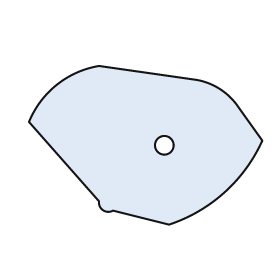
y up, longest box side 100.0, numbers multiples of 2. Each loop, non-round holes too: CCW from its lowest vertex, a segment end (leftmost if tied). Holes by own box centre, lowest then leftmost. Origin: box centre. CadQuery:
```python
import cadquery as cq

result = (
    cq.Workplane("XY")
    .moveTo(10.0, -34.0)
    .threePointArc((34.0, -20.0), (50.0, 2.0))
    .lineTo(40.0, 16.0)
    .threePointArc((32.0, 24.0), (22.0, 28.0))
    .lineTo(-20.0, 34.0)
    .threePointArc((-38.0, 26.0), (-50.0, 10.0))
    .lineTo(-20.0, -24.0)
    .threePointArc((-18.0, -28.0), (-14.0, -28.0))
    .close()
    .moveTo(8.0, 0.0)
    .circle(4.0)
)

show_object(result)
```